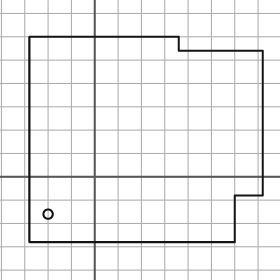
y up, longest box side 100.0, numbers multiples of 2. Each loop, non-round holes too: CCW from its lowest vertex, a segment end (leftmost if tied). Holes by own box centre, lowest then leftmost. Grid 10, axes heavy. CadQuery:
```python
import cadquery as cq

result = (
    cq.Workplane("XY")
    .moveTo(-28.0, -28.0)
    .lineTo(60.0, -28.0)
    .lineTo(60.0, -8.0)
    .lineTo(72.0, -8.0)
    .lineTo(72.0, 54.0)
    .lineTo(36.0, 54.0)
    .lineTo(36.0, 60.0)
    .lineTo(-28.0, 60.0)
    .close()
    .moveTo(-20.0, -16.0)
    .circle(2.0)
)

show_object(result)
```